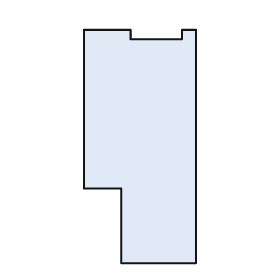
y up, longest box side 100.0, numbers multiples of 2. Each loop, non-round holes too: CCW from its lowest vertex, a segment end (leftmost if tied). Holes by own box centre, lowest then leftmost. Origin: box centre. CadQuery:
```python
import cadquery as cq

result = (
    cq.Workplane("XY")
    .moveTo(-8.0, -50.0)
    .lineTo(24.0, -50.0)
    .lineTo(24.0, 50.0)
    .lineTo(18.0, 50.0)
    .lineTo(18.0, 46.0)
    .lineTo(-4.0, 46.0)
    .lineTo(-4.0, 50.0)
    .lineTo(-24.0, 50.0)
    .lineTo(-24.0, -18.0)
    .lineTo(-8.0, -18.0)
    .close()
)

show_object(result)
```